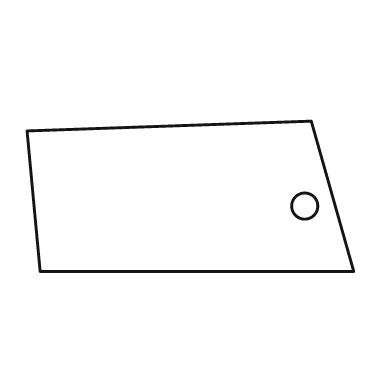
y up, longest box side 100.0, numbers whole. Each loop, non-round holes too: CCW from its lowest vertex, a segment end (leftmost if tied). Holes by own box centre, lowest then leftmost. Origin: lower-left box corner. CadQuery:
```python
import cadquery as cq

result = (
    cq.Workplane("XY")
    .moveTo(4.0, 0.0)
    .lineTo(100.0, 0.0)
    .lineTo(87.0, 46.0)
    .lineTo(0.0, 43.0)
    .close()
    .moveTo(85.0, 20.0)
    .circle(4.0)
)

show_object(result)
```